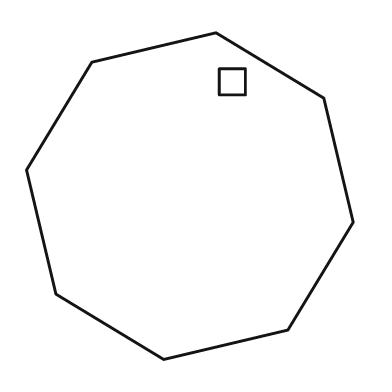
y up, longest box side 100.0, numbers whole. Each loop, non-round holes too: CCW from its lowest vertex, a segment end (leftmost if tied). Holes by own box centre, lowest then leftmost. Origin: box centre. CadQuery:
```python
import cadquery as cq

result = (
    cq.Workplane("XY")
    .moveTo(-8.0, -50.0)
    .lineTo(30.0, -41.0)
    .lineTo(50.0, -8.0)
    .lineTo(41.0, 30.0)
    .lineTo(8.0, 50.0)
    .lineTo(-30.0, 41.0)
    .lineTo(-50.0, 8.0)
    .lineTo(-41.0, -30.0)
    .close()
    .moveTo(9.0, 31.0)
    .lineTo(17.0, 31.0)
    .lineTo(17.0, 39.0)
    .lineTo(9.0, 39.0)
    .close()
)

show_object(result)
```